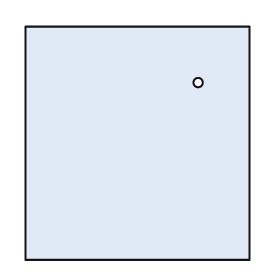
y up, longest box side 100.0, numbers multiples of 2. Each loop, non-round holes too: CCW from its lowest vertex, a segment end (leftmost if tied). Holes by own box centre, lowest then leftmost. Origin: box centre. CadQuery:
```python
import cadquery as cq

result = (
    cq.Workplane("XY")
    .moveTo(-48.0, -50.0)
    .lineTo(48.0, -50.0)
    .lineTo(48.0, 50.0)
    .lineTo(-48.0, 50.0)
    .close()
    .moveTo(26.0, 26.0)
    .circle(2.0)
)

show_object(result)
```